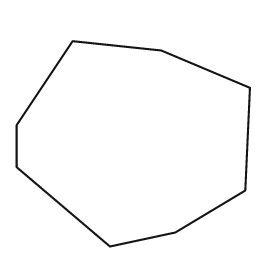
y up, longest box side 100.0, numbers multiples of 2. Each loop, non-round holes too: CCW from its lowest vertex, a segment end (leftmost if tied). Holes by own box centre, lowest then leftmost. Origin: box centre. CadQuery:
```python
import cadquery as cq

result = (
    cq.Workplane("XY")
    .moveTo(-10.0, -44.0)
    .lineTo(18.0, -38.0)
    .lineTo(48.0, -20.0)
    .lineTo(50.0, 24.0)
    .lineTo(12.0, 40.0)
    .lineTo(-26.0, 44.0)
    .lineTo(-50.0, 8.0)
    .lineTo(-50.0, -10.0)
    .close()
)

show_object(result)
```